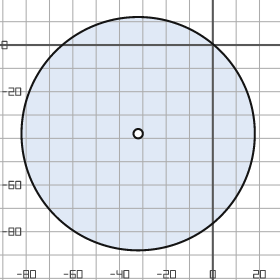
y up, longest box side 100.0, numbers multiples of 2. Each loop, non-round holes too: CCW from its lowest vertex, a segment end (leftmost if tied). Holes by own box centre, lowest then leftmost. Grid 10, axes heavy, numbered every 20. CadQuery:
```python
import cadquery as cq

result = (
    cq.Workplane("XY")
    .moveTo(-32.0, -38.0)
    .circle(50.0)
    .moveTo(-32.0, -38.0)
    .circle(2.0)
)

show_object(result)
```